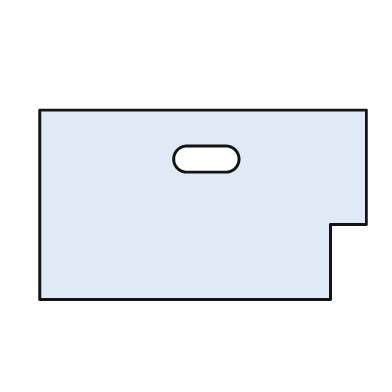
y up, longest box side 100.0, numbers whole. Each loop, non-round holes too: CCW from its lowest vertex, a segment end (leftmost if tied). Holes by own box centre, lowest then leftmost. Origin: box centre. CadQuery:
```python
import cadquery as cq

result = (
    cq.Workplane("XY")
    .moveTo(-50.0, -29.0)
    .lineTo(39.0, -29.0)
    .lineTo(39.0, -6.0)
    .lineTo(50.0, -6.0)
    .lineTo(50.0, 29.0)
    .lineTo(-50.0, 29.0)
    .close()
    .moveTo(-5.0, 10.0)
    .lineTo(7.0, 10.0)
    .threePointArc((11.0, 14.0), (7.0, 18.0))
    .lineTo(-5.0, 18.0)
    .threePointArc((-9.0, 14.0), (-5.0, 10.0))
    .close()
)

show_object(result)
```